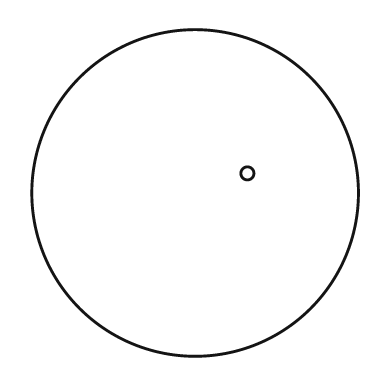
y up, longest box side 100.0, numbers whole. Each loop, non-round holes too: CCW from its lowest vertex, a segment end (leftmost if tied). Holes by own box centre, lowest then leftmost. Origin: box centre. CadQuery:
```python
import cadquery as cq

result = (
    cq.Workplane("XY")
    .moveTo(0.0, 0.0)
    .circle(50.0)
    .moveTo(16.0, 6.0)
    .circle(2.0)
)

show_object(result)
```